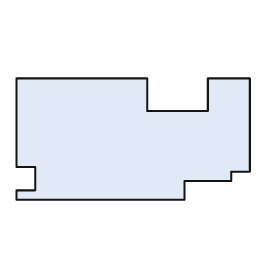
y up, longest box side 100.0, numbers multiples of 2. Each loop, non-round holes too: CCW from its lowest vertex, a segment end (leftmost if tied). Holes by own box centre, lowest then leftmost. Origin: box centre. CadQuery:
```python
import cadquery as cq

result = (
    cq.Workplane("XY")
    .moveTo(-50.0, -26.0)
    .lineTo(22.0, -26.0)
    .lineTo(22.0, -18.0)
    .lineTo(42.0, -18.0)
    .lineTo(42.0, -14.0)
    .lineTo(50.0, -14.0)
    .lineTo(50.0, 26.0)
    .lineTo(32.0, 26.0)
    .lineTo(32.0, 12.0)
    .lineTo(6.0, 12.0)
    .lineTo(6.0, 26.0)
    .lineTo(-50.0, 26.0)
    .lineTo(-50.0, -12.0)
    .lineTo(-42.0, -12.0)
    .lineTo(-42.0, -22.0)
    .lineTo(-50.0, -22.0)
    .close()
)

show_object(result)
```